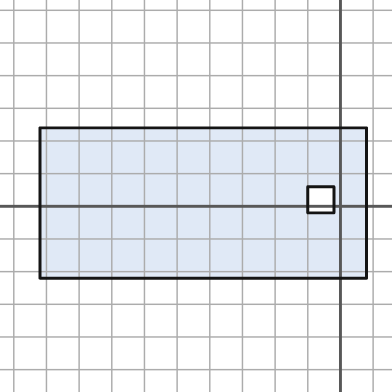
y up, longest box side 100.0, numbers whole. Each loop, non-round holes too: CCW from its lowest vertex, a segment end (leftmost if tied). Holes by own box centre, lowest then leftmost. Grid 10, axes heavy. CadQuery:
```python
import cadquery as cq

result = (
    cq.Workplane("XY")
    .moveTo(-92.0, -22.0)
    .lineTo(8.0, -22.0)
    .lineTo(8.0, 24.0)
    .lineTo(-92.0, 24.0)
    .close()
    .moveTo(-10.0, -2.0)
    .lineTo(-2.0, -2.0)
    .lineTo(-2.0, 6.0)
    .lineTo(-10.0, 6.0)
    .close()
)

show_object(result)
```